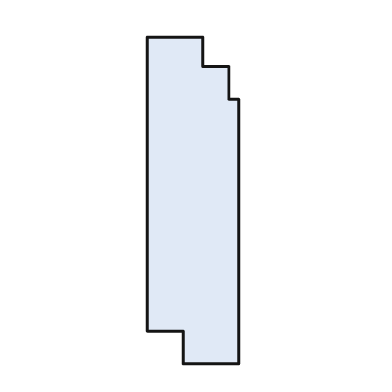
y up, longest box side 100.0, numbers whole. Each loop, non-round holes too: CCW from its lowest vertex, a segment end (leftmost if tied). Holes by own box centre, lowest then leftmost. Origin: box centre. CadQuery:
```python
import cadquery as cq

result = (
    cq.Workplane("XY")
    .moveTo(-3.0, -50.0)
    .lineTo(14.0, -50.0)
    .lineTo(14.0, 31.0)
    .lineTo(11.0, 31.0)
    .lineTo(11.0, 41.0)
    .lineTo(3.0, 41.0)
    .lineTo(3.0, 50.0)
    .lineTo(-14.0, 50.0)
    .lineTo(-14.0, -40.0)
    .lineTo(-3.0, -40.0)
    .close()
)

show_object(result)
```